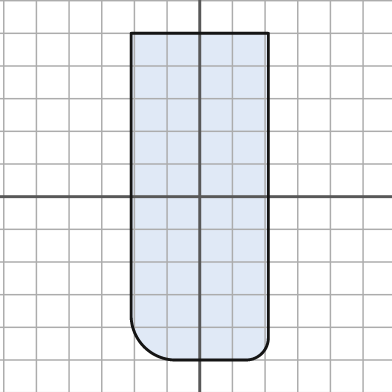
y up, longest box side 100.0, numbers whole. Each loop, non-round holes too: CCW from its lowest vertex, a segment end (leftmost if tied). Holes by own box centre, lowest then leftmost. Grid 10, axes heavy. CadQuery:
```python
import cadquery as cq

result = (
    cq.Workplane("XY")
    .moveTo(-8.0, -50.0)
    .lineTo(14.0, -50.0)
    .threePointArc((19.0, -48.0), (21.0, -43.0))
    .lineTo(21.0, 50.0)
    .lineTo(-21.0, 50.0)
    .lineTo(-21.0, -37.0)
    .threePointArc((-17.0, -46.0), (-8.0, -50.0))
    .close()
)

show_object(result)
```